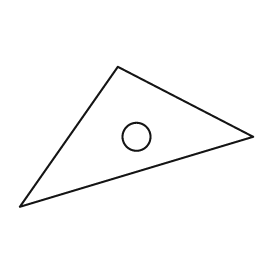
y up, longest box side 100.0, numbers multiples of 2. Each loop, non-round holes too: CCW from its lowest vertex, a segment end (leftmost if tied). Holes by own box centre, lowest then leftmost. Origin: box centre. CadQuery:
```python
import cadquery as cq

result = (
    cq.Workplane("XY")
    .moveTo(-50.0, -30.0)
    .lineTo(50.0, 0.0)
    .lineTo(-8.0, 30.0)
    .close()
    .moveTo(0.0, 0.0)
    .circle(6.0)
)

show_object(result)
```